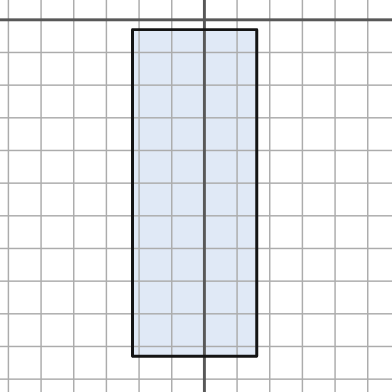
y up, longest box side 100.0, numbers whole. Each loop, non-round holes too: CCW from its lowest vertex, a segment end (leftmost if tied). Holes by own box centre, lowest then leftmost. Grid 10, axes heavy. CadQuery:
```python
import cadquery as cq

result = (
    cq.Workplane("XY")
    .moveTo(-22.0, -103.0)
    .lineTo(16.0, -103.0)
    .lineTo(16.0, -3.0)
    .lineTo(-22.0, -3.0)
    .close()
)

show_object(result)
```